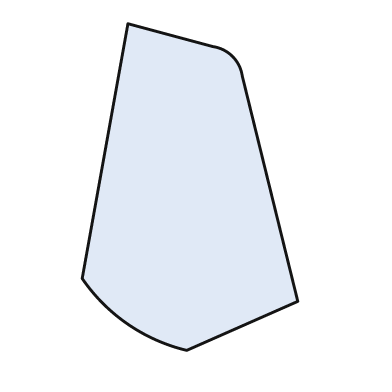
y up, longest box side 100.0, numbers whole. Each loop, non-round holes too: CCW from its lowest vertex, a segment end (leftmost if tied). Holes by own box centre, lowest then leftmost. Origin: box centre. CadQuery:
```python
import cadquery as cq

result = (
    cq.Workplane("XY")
    .moveTo(-1.0, -50.0)
    .lineTo(33.0, -35.0)
    .lineTo(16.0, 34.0)
    .threePointArc((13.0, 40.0), (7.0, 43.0))
    .lineTo(-19.0, 50.0)
    .lineTo(-33.0, -28.0)
    .threePointArc((-19.0, -42.0), (-1.0, -50.0))
    .close()
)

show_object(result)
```